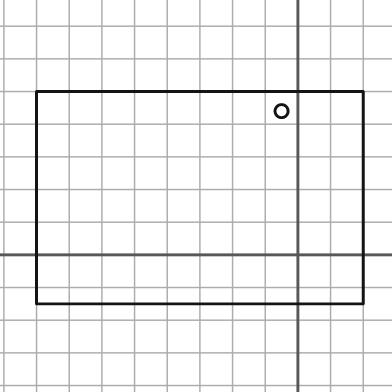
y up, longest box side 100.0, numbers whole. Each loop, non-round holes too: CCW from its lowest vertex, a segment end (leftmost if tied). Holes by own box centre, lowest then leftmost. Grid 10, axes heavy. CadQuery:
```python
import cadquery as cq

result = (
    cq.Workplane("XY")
    .moveTo(-80.0, -15.0)
    .lineTo(20.0, -15.0)
    .lineTo(20.0, 50.0)
    .lineTo(-80.0, 50.0)
    .close()
    .moveTo(-5.0, 44.0)
    .circle(2.0)
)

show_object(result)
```